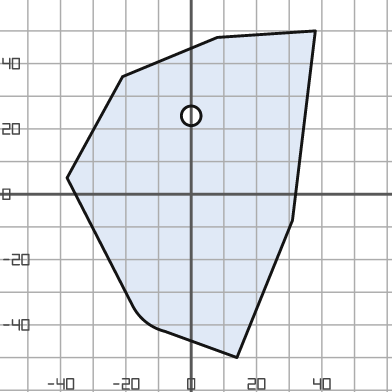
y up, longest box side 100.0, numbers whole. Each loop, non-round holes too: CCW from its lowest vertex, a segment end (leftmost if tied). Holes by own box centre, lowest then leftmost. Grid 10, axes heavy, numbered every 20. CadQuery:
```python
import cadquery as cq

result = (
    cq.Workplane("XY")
    .moveTo(14.0, -50.0)
    .lineTo(31.0, -8.0)
    .lineTo(38.0, 50.0)
    .lineTo(8.0, 48.0)
    .lineTo(-21.0, 36.0)
    .lineTo(-38.0, 5.0)
    .lineTo(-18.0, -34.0)
    .threePointArc((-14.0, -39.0), (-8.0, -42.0))
    .close()
    .moveTo(0.0, 24.0)
    .circle(3.0)
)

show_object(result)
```